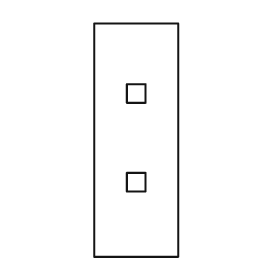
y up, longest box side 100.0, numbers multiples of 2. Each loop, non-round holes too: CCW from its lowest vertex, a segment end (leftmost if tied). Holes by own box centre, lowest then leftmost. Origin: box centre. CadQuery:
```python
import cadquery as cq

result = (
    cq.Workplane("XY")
    .moveTo(-18.0, -50.0)
    .lineTo(18.0, -50.0)
    .lineTo(18.0, 50.0)
    .lineTo(-18.0, 50.0)
    .close()
    .moveTo(-4.0, -22.0)
    .lineTo(4.0, -22.0)
    .lineTo(4.0, -14.0)
    .lineTo(-4.0, -14.0)
    .close()
    .moveTo(-4.0, 16.0)
    .lineTo(4.0, 16.0)
    .lineTo(4.0, 24.0)
    .lineTo(-4.0, 24.0)
    .close()
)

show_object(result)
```